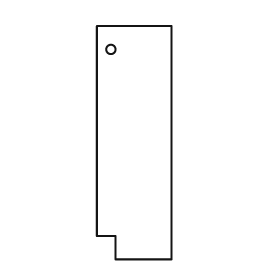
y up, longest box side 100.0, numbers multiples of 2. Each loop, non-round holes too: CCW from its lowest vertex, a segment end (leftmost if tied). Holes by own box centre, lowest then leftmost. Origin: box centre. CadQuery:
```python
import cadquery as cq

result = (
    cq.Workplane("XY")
    .moveTo(-8.0, -50.0)
    .lineTo(16.0, -50.0)
    .lineTo(16.0, 50.0)
    .lineTo(-16.0, 50.0)
    .lineTo(-16.0, -40.0)
    .lineTo(-8.0, -40.0)
    .close()
    .moveTo(-10.0, 40.0)
    .circle(2.0)
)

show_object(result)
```